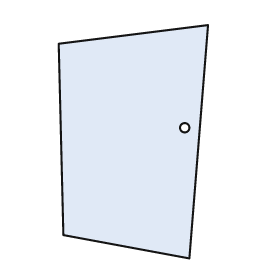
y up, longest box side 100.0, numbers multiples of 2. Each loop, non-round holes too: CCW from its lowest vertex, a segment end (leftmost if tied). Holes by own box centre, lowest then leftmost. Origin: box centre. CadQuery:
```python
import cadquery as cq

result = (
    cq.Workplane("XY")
    .moveTo(24.0, -50.0)
    .lineTo(32.0, 50.0)
    .lineTo(-32.0, 42.0)
    .lineTo(-30.0, -40.0)
    .close()
    .moveTo(22.0, 6.0)
    .circle(2.0)
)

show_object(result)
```